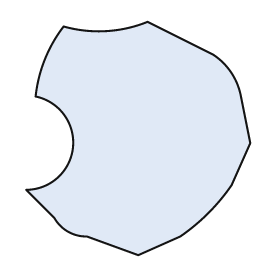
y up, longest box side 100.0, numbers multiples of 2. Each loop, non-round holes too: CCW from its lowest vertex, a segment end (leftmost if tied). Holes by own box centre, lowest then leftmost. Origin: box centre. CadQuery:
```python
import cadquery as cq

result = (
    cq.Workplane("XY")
    .moveTo(0.0, -50.0)
    .lineTo(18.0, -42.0)
    .threePointArc((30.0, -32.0), (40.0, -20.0))
    .lineTo(48.0, -2.0)
    .lineTo(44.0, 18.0)
    .threePointArc((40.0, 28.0), (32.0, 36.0))
    .lineTo(4.0, 50.0)
    .threePointArc((-14.0, 46.0), (-32.0, 48.0))
    .threePointArc((-40.0, 34.0), (-44.0, 18.0))
    .threePointArc((-28.0, -4.0), (-48.0, -22.0))
    .lineTo(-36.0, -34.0)
    .threePointArc((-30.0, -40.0), (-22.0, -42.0))
    .close()
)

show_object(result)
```